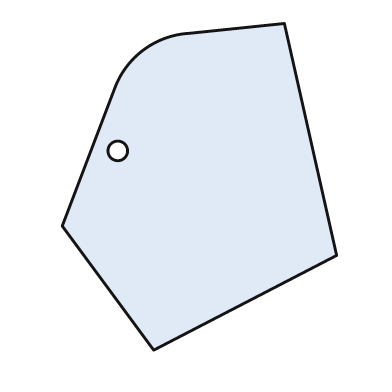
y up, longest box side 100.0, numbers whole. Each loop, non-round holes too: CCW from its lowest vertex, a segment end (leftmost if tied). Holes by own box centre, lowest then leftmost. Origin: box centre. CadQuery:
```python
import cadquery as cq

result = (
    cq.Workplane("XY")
    .moveTo(-14.0, -50.0)
    .lineTo(42.0, -21.0)
    .lineTo(26.0, 50.0)
    .lineTo(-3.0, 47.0)
    .threePointArc((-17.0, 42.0), (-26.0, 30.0))
    .lineTo(-42.0, -12.0)
    .close()
    .moveTo(-25.0, 11.0)
    .circle(3.0)
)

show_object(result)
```